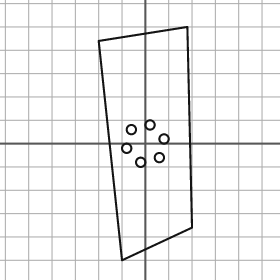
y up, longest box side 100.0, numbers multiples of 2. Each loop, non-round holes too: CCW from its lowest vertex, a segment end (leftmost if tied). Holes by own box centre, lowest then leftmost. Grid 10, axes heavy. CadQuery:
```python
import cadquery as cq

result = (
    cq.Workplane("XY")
    .moveTo(-10.0, -50.0)
    .lineTo(20.0, -36.0)
    .lineTo(18.0, 50.0)
    .lineTo(-20.0, 44.0)
    .close()
    .moveTo(-2.0, -8.0)
    .circle(2.0)
    .moveTo(6.0, -6.0)
    .circle(2.0)
    .moveTo(-8.0, -2.0)
    .circle(2.0)
    .moveTo(8.0, 2.0)
    .circle(2.0)
    .moveTo(-6.0, 6.0)
    .circle(2.0)
    .moveTo(2.0, 8.0)
    .circle(2.0)
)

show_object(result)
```